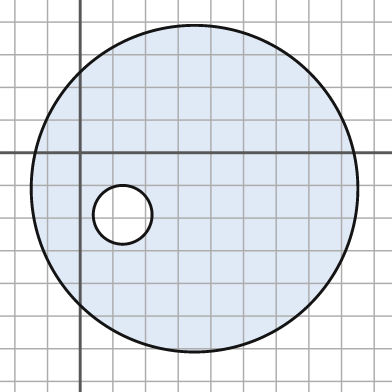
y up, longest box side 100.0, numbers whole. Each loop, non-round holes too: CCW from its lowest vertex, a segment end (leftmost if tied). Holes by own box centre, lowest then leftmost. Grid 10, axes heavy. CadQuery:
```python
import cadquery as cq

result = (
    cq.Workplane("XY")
    .moveTo(35.0, -11.0)
    .circle(50.0)
    .moveTo(13.0, -19.0)
    .circle(9.0)
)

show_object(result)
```